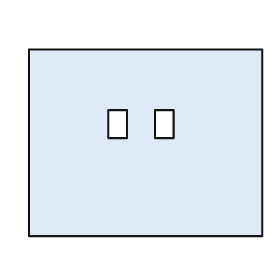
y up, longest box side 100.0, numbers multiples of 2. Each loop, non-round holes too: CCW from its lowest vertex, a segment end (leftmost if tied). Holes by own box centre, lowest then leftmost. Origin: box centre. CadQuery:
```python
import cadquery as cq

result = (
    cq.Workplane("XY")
    .moveTo(-50.0, -40.0)
    .lineTo(50.0, -40.0)
    .lineTo(50.0, 40.0)
    .lineTo(-50.0, 40.0)
    .close()
    .moveTo(-16.0, 2.0)
    .lineTo(-8.0, 2.0)
    .lineTo(-8.0, 14.0)
    .lineTo(-16.0, 14.0)
    .close()
    .moveTo(4.0, 2.0)
    .lineTo(12.0, 2.0)
    .lineTo(12.0, 14.0)
    .lineTo(4.0, 14.0)
    .close()
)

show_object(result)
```